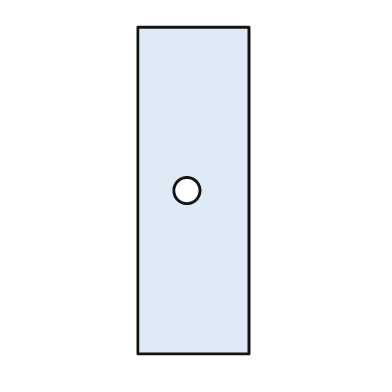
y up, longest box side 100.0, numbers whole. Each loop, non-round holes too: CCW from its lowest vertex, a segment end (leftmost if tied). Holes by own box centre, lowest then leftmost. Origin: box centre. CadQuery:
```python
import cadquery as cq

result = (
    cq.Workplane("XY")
    .moveTo(-17.0, -50.0)
    .lineTo(17.0, -50.0)
    .lineTo(17.0, 50.0)
    .lineTo(-17.0, 50.0)
    .close()
    .moveTo(-2.0, 0.0)
    .circle(4.0)
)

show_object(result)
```